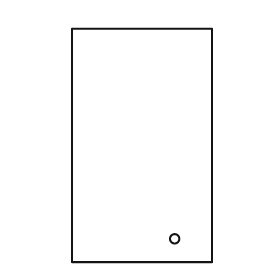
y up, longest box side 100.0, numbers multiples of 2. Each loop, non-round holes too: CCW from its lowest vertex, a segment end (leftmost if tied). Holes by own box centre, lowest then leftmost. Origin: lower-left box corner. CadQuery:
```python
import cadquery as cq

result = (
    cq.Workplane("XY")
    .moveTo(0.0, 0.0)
    .lineTo(60.0, 0.0)
    .lineTo(60.0, 100.0)
    .lineTo(0.0, 100.0)
    .close()
    .moveTo(44.0, 10.0)
    .circle(2.0)
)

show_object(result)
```